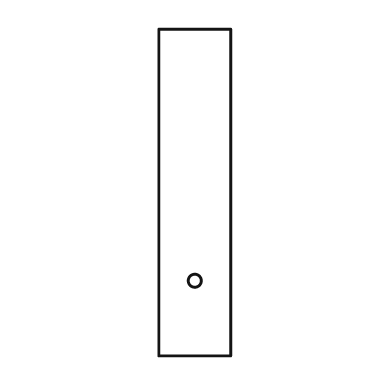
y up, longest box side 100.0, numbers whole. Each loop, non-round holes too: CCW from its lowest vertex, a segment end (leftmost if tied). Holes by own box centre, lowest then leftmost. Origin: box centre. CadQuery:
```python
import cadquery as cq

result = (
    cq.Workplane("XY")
    .moveTo(-11.0, -50.0)
    .lineTo(11.0, -50.0)
    .lineTo(11.0, 50.0)
    .lineTo(-11.0, 50.0)
    .close()
    .moveTo(0.0, -27.0)
    .circle(2.0)
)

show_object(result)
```